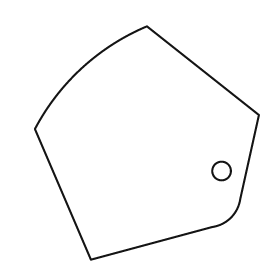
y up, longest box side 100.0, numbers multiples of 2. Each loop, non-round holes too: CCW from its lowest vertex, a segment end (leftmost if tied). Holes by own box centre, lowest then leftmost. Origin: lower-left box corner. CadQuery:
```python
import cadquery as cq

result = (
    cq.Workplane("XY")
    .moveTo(24.0, 0.0)
    .lineTo(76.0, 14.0)
    .threePointArc((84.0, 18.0), (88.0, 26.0))
    .lineTo(96.0, 62.0)
    .lineTo(48.0, 100.0)
    .threePointArc((20.0, 82.0), (0.0, 56.0))
    .close()
    .moveTo(80.0, 38.0)
    .circle(4.0)
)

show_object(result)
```